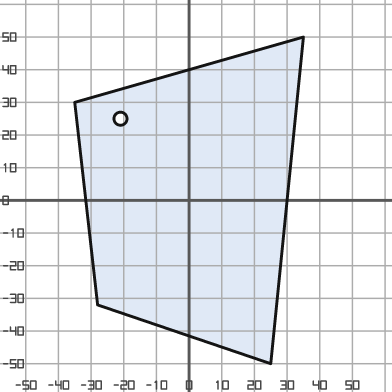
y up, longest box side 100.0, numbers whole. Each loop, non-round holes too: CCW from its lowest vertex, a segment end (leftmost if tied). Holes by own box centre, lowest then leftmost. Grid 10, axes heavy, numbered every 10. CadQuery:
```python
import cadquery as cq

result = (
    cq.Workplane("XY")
    .moveTo(25.0, -50.0)
    .lineTo(35.0, 50.0)
    .lineTo(-35.0, 30.0)
    .lineTo(-28.0, -32.0)
    .close()
    .moveTo(-21.0, 25.0)
    .circle(2.0)
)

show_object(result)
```